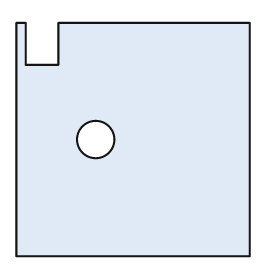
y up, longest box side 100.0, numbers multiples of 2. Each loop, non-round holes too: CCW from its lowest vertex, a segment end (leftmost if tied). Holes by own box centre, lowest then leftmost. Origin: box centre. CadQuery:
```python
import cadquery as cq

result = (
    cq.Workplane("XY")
    .moveTo(-50.0, -50.0)
    .lineTo(50.0, -50.0)
    .lineTo(50.0, 50.0)
    .lineTo(-32.0, 50.0)
    .lineTo(-32.0, 32.0)
    .lineTo(-46.0, 32.0)
    .lineTo(-46.0, 50.0)
    .lineTo(-50.0, 50.0)
    .close()
    .moveTo(-16.0, 0.0)
    .circle(8.0)
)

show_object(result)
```